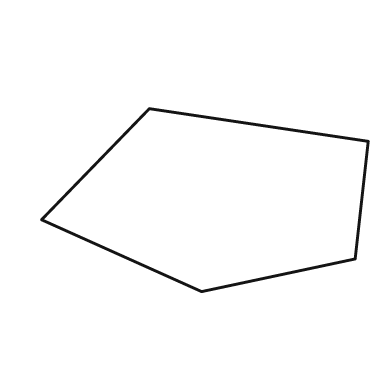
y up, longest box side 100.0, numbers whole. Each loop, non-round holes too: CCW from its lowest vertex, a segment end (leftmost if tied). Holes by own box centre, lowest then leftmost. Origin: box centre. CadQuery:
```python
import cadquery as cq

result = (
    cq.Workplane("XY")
    .moveTo(-1.0, -28.0)
    .lineTo(46.0, -18.0)
    .lineTo(50.0, 18.0)
    .lineTo(-17.0, 28.0)
    .lineTo(-50.0, -6.0)
    .close()
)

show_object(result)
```